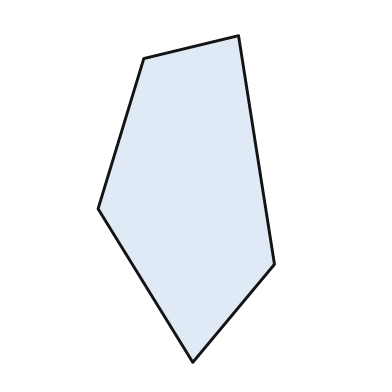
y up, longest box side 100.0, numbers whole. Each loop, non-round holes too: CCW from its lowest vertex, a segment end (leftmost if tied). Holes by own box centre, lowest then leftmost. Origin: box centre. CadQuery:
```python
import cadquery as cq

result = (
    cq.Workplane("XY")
    .moveTo(2.0, -50.0)
    .lineTo(27.0, -20.0)
    .lineTo(16.0, 50.0)
    .lineTo(-13.0, 43.0)
    .lineTo(-27.0, -3.0)
    .close()
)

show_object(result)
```